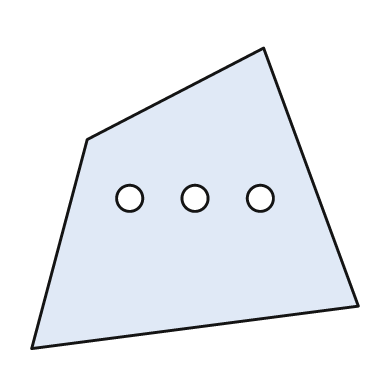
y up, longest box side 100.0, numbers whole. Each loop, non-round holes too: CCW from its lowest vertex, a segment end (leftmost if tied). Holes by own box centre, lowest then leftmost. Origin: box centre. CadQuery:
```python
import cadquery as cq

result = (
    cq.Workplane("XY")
    .moveTo(-50.0, -46.0)
    .lineTo(50.0, -33.0)
    .lineTo(21.0, 46.0)
    .lineTo(-33.0, 18.0)
    .close()
    .moveTo(-20.0, 0.0)
    .circle(4.0)
    .moveTo(0.0, 0.0)
    .circle(4.0)
    .moveTo(20.0, 0.0)
    .circle(4.0)
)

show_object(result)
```